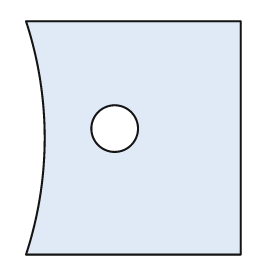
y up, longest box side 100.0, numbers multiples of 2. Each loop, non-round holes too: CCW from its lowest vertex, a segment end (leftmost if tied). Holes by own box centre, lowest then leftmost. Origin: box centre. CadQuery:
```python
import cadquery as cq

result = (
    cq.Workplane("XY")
    .moveTo(-46.0, -50.0)
    .lineTo(46.0, -50.0)
    .lineTo(46.0, 50.0)
    .lineTo(-46.0, 50.0)
    .threePointArc((-38.0, 0.0), (-46.0, -50.0))
    .close()
    .moveTo(-8.0, 4.0)
    .circle(10.0)
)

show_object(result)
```